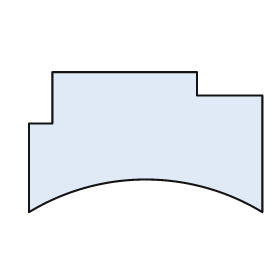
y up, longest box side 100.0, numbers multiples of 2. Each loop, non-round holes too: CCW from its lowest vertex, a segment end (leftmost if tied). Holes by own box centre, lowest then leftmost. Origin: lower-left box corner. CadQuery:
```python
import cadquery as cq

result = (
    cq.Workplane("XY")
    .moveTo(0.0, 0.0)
    .threePointArc((50.0, 14.0), (100.0, 0.0))
    .lineTo(100.0, 50.0)
    .lineTo(72.0, 50.0)
    .lineTo(72.0, 60.0)
    .lineTo(10.0, 60.0)
    .lineTo(10.0, 38.0)
    .lineTo(0.0, 38.0)
    .close()
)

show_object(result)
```